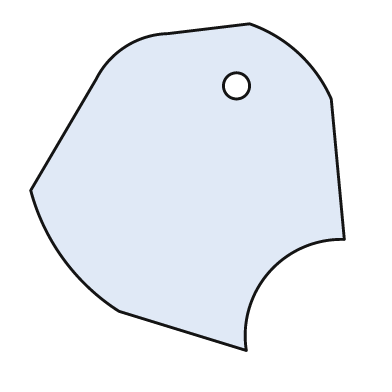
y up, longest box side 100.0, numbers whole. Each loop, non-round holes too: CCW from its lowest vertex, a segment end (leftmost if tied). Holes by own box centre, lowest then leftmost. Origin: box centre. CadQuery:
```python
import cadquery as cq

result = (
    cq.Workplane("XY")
    .moveTo(18.0, -50.0)
    .threePointArc((25.0, -26.0), (48.0, -16.0))
    .lineTo(44.0, 27.0)
    .threePointArc((34.0, 41.0), (19.0, 50.0))
    .lineTo(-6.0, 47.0)
    .threePointArc((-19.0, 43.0), (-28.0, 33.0))
    .lineTo(-48.0, -1.0)
    .threePointArc((-38.0, -22.0), (-21.0, -38.0))
    .close()
    .moveTo(15.0, 31.0)
    .circle(4.0)
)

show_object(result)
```